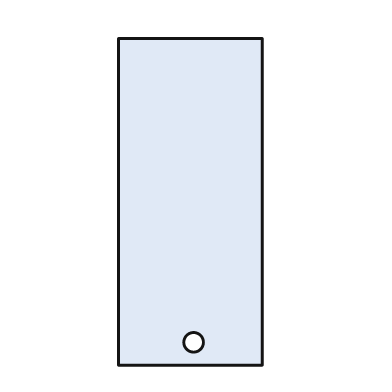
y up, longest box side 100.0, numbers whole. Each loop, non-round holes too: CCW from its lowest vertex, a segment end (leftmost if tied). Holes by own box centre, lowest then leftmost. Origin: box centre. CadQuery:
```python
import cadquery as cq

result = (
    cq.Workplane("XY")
    .moveTo(-22.0, -50.0)
    .lineTo(22.0, -50.0)
    .lineTo(22.0, 50.0)
    .lineTo(-22.0, 50.0)
    .close()
    .moveTo(1.0, -43.0)
    .circle(3.0)
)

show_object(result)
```